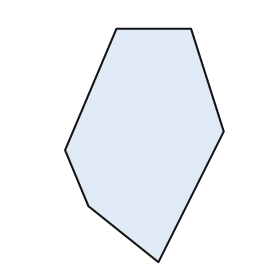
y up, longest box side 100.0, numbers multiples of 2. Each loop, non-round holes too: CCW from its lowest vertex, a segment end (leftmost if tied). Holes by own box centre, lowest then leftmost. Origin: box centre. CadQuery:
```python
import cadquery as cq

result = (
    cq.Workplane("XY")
    .moveTo(6.0, -50.0)
    .lineTo(34.0, 6.0)
    .lineTo(20.0, 50.0)
    .lineTo(-12.0, 50.0)
    .lineTo(-34.0, -2.0)
    .lineTo(-24.0, -26.0)
    .close()
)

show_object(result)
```